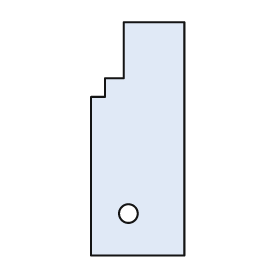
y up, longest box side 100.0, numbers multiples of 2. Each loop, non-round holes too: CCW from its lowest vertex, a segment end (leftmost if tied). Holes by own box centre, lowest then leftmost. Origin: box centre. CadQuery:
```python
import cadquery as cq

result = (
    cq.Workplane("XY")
    .moveTo(-20.0, -50.0)
    .lineTo(20.0, -50.0)
    .lineTo(20.0, 50.0)
    .lineTo(-6.0, 50.0)
    .lineTo(-6.0, 26.0)
    .lineTo(-14.0, 26.0)
    .lineTo(-14.0, 18.0)
    .lineTo(-20.0, 18.0)
    .close()
    .moveTo(-4.0, -32.0)
    .circle(4.0)
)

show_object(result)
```